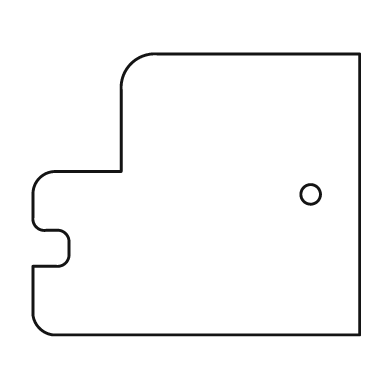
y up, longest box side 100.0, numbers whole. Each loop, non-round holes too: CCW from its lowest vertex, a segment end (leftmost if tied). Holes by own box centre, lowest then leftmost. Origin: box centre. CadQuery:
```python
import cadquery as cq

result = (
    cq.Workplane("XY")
    .moveTo(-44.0, -43.0)
    .lineTo(50.0, -43.0)
    .lineTo(50.0, 43.0)
    .lineTo(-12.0, 43.0)
    .threePointArc((-20.0, 40.0), (-23.0, 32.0))
    .lineTo(-23.0, 7.0)
    .lineTo(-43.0, 7.0)
    .threePointArc((-48.0, 5.0), (-50.0, 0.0))
    .lineTo(-50.0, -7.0)
    .threePointArc((-49.0, -10.0), (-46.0, -11.0))
    .lineTo(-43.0, -11.0)
    .threePointArc((-40.0, -12.0), (-39.0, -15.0))
    .lineTo(-39.0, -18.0)
    .threePointArc((-40.0, -21.0), (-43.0, -22.0))
    .lineTo(-50.0, -22.0)
    .lineTo(-50.0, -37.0)
    .threePointArc((-48.0, -41.0), (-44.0, -43.0))
    .close()
    .moveTo(35.0, 0.0)
    .circle(3.0)
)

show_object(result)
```